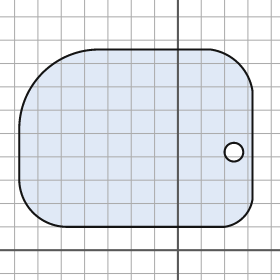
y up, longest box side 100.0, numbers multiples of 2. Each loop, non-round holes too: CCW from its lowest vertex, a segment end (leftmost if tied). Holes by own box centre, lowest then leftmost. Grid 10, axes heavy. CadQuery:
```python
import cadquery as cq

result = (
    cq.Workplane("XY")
    .moveTo(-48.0, 10.0)
    .lineTo(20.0, 10.0)
    .threePointArc((28.0, 14.0), (32.0, 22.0))
    .lineTo(32.0, 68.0)
    .threePointArc((26.0, 80.0), (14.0, 86.0))
    .lineTo(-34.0, 86.0)
    .threePointArc((-58.0, 76.0), (-68.0, 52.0))
    .lineTo(-68.0, 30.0)
    .threePointArc((-62.0, 16.0), (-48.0, 10.0))
    .close()
    .moveTo(24.0, 42.0)
    .circle(4.0)
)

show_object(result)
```